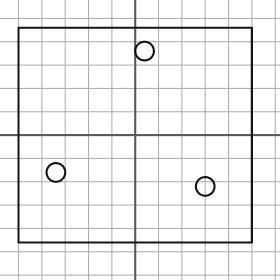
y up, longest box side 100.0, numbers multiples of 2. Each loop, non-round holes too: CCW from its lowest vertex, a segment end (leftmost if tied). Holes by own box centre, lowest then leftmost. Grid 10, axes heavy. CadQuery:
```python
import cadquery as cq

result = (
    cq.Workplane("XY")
    .moveTo(-50.0, -46.0)
    .lineTo(50.0, -46.0)
    .lineTo(50.0, 46.0)
    .lineTo(-50.0, 46.0)
    .close()
    .moveTo(30.0, -22.0)
    .circle(4.0)
    .moveTo(-34.0, -16.0)
    .circle(4.0)
    .moveTo(4.0, 36.0)
    .circle(4.0)
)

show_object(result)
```